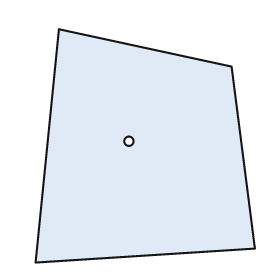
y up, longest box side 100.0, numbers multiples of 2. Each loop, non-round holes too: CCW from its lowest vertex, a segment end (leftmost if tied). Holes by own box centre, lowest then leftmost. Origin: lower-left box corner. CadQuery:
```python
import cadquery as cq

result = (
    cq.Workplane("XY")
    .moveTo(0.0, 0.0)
    .lineTo(94.0, 6.0)
    .lineTo(84.0, 84.0)
    .lineTo(10.0, 100.0)
    .close()
    .moveTo(40.0, 52.0)
    .circle(2.0)
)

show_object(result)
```